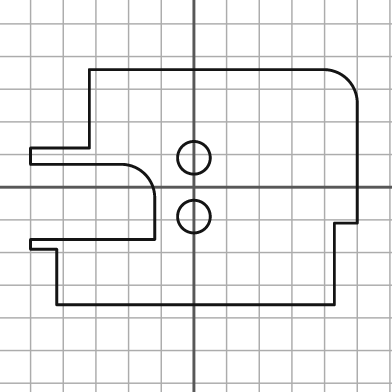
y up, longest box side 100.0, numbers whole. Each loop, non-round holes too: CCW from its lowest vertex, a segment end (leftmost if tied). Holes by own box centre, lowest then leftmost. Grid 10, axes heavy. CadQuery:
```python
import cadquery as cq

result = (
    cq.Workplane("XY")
    .moveTo(-42.0, -36.0)
    .lineTo(43.0, -36.0)
    .lineTo(43.0, -11.0)
    .lineTo(50.0, -11.0)
    .lineTo(50.0, 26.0)
    .threePointArc((47.0, 33.0), (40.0, 36.0))
    .lineTo(-32.0, 36.0)
    .lineTo(-32.0, 12.0)
    .lineTo(-50.0, 12.0)
    .lineTo(-50.0, 7.0)
    .lineTo(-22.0, 7.0)
    .threePointArc((-15.0, 4.0), (-12.0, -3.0))
    .lineTo(-12.0, -16.0)
    .lineTo(-50.0, -16.0)
    .lineTo(-50.0, -19.0)
    .lineTo(-42.0, -19.0)
    .close()
    .moveTo(0.0, -9.0)
    .circle(5.0)
    .moveTo(0.0, 9.0)
    .circle(5.0)
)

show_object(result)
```